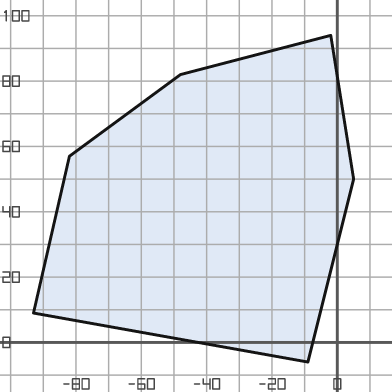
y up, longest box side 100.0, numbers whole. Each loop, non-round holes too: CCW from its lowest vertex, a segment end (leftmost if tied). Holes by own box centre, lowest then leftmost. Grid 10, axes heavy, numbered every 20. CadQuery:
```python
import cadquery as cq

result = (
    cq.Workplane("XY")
    .moveTo(-9.0, -6.0)
    .lineTo(5.0, 50.0)
    .lineTo(-2.0, 94.0)
    .lineTo(-48.0, 82.0)
    .lineTo(-82.0, 57.0)
    .lineTo(-93.0, 9.0)
    .close()
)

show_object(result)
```